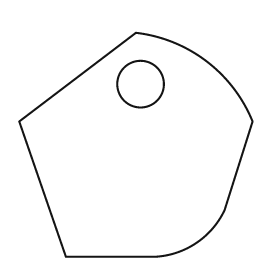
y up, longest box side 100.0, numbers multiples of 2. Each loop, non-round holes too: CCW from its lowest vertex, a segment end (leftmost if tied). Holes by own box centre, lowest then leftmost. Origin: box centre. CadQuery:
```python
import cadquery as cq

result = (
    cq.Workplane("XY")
    .moveTo(-30.0, -48.0)
    .lineTo(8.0, -48.0)
    .threePointArc((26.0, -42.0), (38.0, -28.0))
    .lineTo(50.0, 10.0)
    .threePointArc((30.0, 36.0), (0.0, 48.0))
    .lineTo(-50.0, 10.0)
    .close()
    .moveTo(2.0, 26.0)
    .circle(10.0)
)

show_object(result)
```